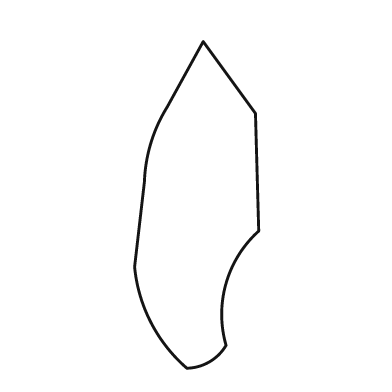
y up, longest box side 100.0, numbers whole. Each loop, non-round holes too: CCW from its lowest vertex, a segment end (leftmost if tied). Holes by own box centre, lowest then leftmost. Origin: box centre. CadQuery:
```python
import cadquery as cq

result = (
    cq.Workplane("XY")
    .moveTo(-3.0, -50.0)
    .threePointArc((4.0, -48.0), (9.0, -43.0))
    .threePointArc((9.0, -24.0), (19.0, -8.0))
    .lineTo(18.0, 28.0)
    .lineTo(2.0, 50.0)
    .lineTo(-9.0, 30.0)
    .threePointArc((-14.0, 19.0), (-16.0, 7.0))
    .lineTo(-19.0, -19.0)
    .threePointArc((-14.0, -36.0), (-3.0, -50.0))
    .close()
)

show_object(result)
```